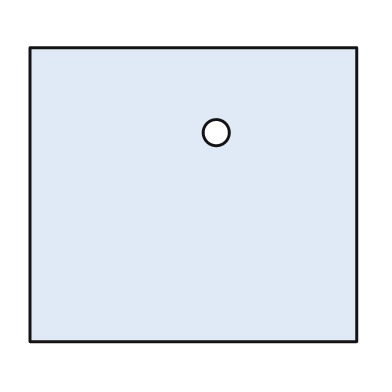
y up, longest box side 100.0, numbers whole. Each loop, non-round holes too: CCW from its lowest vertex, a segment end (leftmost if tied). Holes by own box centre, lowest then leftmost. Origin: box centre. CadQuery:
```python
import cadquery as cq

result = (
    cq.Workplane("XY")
    .moveTo(-50.0, -45.0)
    .lineTo(50.0, -45.0)
    .lineTo(50.0, 45.0)
    .lineTo(-50.0, 45.0)
    .close()
    .moveTo(7.0, 19.0)
    .circle(4.0)
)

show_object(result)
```